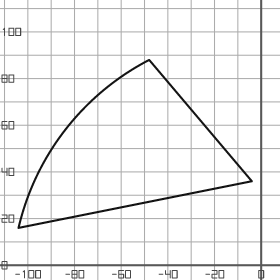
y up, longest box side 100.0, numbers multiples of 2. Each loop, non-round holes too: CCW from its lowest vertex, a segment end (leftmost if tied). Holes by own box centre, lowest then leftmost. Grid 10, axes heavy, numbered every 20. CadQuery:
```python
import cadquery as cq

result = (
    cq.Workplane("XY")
    .moveTo(-104.0, 16.0)
    .lineTo(-4.0, 36.0)
    .lineTo(-48.0, 88.0)
    .threePointArc((-84.0, 58.0), (-104.0, 16.0))
    .close()
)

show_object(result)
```